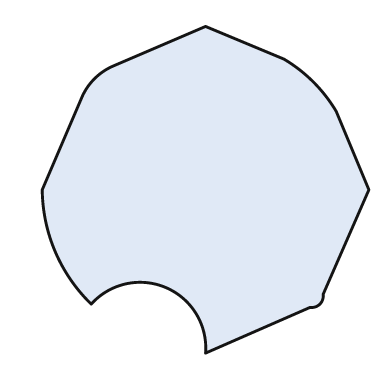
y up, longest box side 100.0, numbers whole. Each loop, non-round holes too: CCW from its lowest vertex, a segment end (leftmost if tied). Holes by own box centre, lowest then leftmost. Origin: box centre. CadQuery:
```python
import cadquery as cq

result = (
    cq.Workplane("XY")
    .moveTo(0.0, -50.0)
    .lineTo(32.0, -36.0)
    .threePointArc((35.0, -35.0), (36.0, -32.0))
    .lineTo(50.0, 0.0)
    .lineTo(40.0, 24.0)
    .threePointArc((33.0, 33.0), (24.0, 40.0))
    .lineTo(0.0, 50.0)
    .lineTo(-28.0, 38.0)
    .threePointArc((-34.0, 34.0), (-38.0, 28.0))
    .lineTo(-50.0, 0.0)
    .threePointArc((-46.0, -19.0), (-35.0, -35.0))
    .threePointArc((-12.0, -30.0), (0.0, -50.0))
    .close()
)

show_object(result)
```